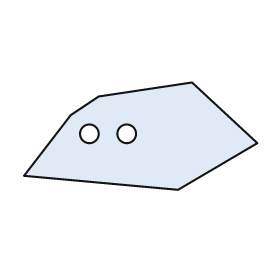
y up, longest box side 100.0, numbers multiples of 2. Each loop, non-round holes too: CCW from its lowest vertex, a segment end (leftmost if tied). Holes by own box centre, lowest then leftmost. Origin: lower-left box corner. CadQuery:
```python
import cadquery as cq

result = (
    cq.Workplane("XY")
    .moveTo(66.0, 0.0)
    .lineTo(100.0, 20.0)
    .lineTo(72.0, 46.0)
    .lineTo(32.0, 40.0)
    .lineTo(20.0, 32.0)
    .lineTo(0.0, 6.0)
    .close()
    .moveTo(28.0, 24.0)
    .circle(4.0)
    .moveTo(44.0, 24.0)
    .circle(4.0)
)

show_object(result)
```